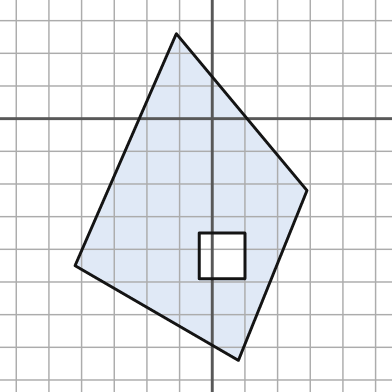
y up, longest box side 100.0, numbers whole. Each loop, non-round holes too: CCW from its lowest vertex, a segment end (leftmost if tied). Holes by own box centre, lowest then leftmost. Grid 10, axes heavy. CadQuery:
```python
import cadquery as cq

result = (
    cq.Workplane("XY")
    .moveTo(8.0, -74.0)
    .lineTo(29.0, -22.0)
    .lineTo(-11.0, 26.0)
    .lineTo(-42.0, -45.0)
    .close()
    .moveTo(-4.0, -49.0)
    .lineTo(10.0, -49.0)
    .lineTo(10.0, -35.0)
    .lineTo(-4.0, -35.0)
    .close()
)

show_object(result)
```